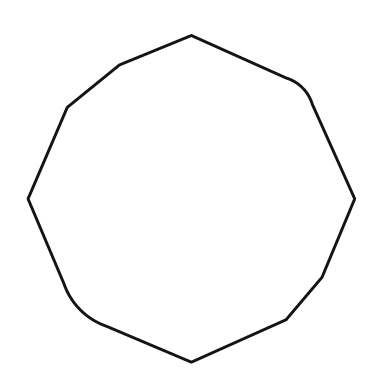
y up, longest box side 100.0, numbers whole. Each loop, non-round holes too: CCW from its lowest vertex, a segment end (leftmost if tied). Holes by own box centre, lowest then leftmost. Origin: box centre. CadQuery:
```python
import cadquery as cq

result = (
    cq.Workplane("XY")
    .moveTo(0.0, -50.0)
    .lineTo(29.0, -37.0)
    .lineTo(40.0, -24.0)
    .lineTo(50.0, 0.0)
    .lineTo(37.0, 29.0)
    .threePointArc((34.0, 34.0), (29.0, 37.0))
    .lineTo(0.0, 50.0)
    .lineTo(-22.0, 41.0)
    .lineTo(-38.0, 28.0)
    .lineTo(-50.0, 0.0)
    .lineTo(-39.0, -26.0)
    .threePointArc((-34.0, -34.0), (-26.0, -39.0))
    .close()
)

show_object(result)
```